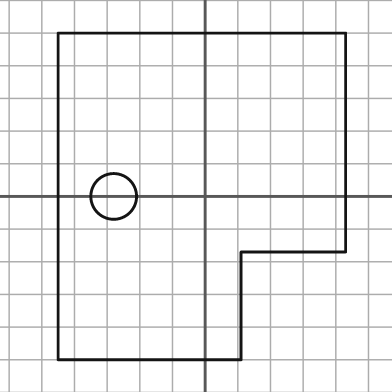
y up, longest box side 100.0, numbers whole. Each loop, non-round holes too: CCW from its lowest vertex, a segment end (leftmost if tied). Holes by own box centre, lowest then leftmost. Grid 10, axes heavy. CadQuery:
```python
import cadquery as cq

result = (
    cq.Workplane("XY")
    .moveTo(-45.0, -50.0)
    .lineTo(11.0, -50.0)
    .lineTo(11.0, -17.0)
    .lineTo(43.0, -17.0)
    .lineTo(43.0, 50.0)
    .lineTo(-45.0, 50.0)
    .close()
    .moveTo(-28.0, 0.0)
    .circle(7.0)
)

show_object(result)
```